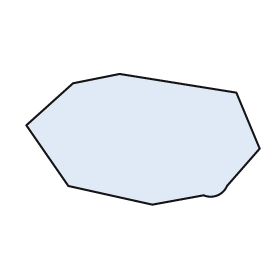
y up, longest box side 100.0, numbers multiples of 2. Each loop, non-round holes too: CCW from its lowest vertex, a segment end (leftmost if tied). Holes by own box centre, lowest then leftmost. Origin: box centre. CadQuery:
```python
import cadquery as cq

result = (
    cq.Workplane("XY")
    .moveTo(4.0, -28.0)
    .lineTo(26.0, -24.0)
    .threePointArc((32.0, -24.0), (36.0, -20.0))
    .lineTo(50.0, -4.0)
    .lineTo(40.0, 20.0)
    .lineTo(-10.0, 28.0)
    .lineTo(-30.0, 24.0)
    .lineTo(-50.0, 6.0)
    .lineTo(-32.0, -20.0)
    .close()
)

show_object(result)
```